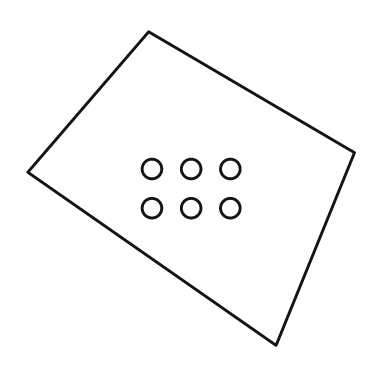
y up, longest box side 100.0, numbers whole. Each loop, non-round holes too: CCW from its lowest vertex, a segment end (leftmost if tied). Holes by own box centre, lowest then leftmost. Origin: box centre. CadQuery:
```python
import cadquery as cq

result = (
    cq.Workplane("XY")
    .moveTo(26.0, -48.0)
    .lineTo(50.0, 11.0)
    .lineTo(-13.0, 48.0)
    .lineTo(-50.0, 5.0)
    .close()
    .moveTo(-12.0, -6.0)
    .circle(3.0)
    .moveTo(0.0, -6.0)
    .circle(3.0)
    .moveTo(12.0, -6.0)
    .circle(3.0)
    .moveTo(-12.0, 6.0)
    .circle(3.0)
    .moveTo(0.0, 6.0)
    .circle(3.0)
    .moveTo(12.0, 6.0)
    .circle(3.0)
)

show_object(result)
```